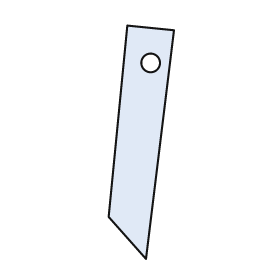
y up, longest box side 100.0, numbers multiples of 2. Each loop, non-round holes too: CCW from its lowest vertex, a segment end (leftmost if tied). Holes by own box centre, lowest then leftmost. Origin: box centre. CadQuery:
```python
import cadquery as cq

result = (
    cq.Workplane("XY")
    .moveTo(2.0, -50.0)
    .lineTo(14.0, 48.0)
    .lineTo(-6.0, 50.0)
    .lineTo(-14.0, -32.0)
    .close()
    .moveTo(4.0, 34.0)
    .circle(4.0)
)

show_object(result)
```